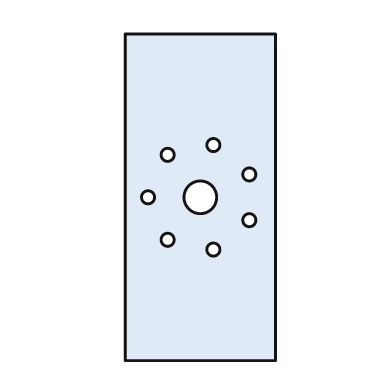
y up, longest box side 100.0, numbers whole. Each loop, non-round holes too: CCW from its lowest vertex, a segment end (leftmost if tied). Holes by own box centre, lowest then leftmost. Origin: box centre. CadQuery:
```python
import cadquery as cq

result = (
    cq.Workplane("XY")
    .moveTo(-23.0, -50.0)
    .lineTo(23.0, -50.0)
    .lineTo(23.0, 50.0)
    .lineTo(-23.0, 50.0)
    .close()
    .moveTo(4.0, -16.0)
    .circle(2.0)
    .moveTo(-10.0, -13.0)
    .circle(2.0)
    .moveTo(15.0, -7.0)
    .circle(2.0)
    .moveTo(-16.0, 0.0)
    .circle(2.0)
    .moveTo(0.0, 0.0)
    .circle(5.0)
    .moveTo(15.0, 7.0)
    .circle(2.0)
    .moveTo(-10.0, 13.0)
    .circle(2.0)
    .moveTo(4.0, 16.0)
    .circle(2.0)
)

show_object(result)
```